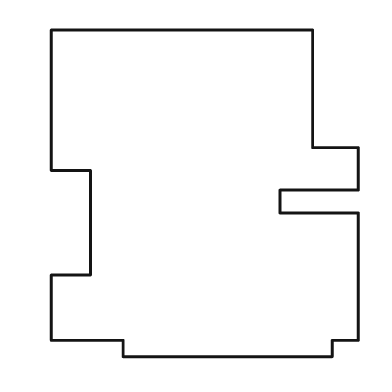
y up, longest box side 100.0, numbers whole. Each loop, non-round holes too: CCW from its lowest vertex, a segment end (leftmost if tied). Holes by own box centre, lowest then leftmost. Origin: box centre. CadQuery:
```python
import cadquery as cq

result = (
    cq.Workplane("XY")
    .moveTo(-25.0, -50.0)
    .lineTo(39.0, -50.0)
    .lineTo(39.0, -45.0)
    .lineTo(47.0, -45.0)
    .lineTo(47.0, -6.0)
    .lineTo(23.0, -6.0)
    .lineTo(23.0, 1.0)
    .lineTo(47.0, 1.0)
    .lineTo(47.0, 14.0)
    .lineTo(33.0, 14.0)
    .lineTo(33.0, 50.0)
    .lineTo(-47.0, 50.0)
    .lineTo(-47.0, 7.0)
    .lineTo(-35.0, 7.0)
    .lineTo(-35.0, -25.0)
    .lineTo(-47.0, -25.0)
    .lineTo(-47.0, -45.0)
    .lineTo(-25.0, -45.0)
    .close()
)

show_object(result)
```